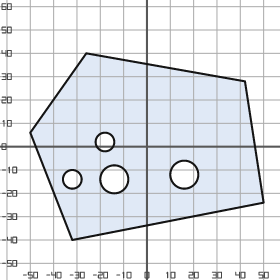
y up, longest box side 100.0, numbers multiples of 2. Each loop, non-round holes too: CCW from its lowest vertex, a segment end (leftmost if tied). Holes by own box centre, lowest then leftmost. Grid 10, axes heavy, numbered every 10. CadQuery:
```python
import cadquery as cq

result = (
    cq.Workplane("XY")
    .moveTo(-32.0, -40.0)
    .lineTo(50.0, -24.0)
    .lineTo(42.0, 28.0)
    .lineTo(-26.0, 40.0)
    .lineTo(-50.0, 6.0)
    .close()
    .moveTo(-32.0, -14.0)
    .circle(4.0)
    .moveTo(-14.0, -14.0)
    .circle(6.0)
    .moveTo(16.0, -12.0)
    .circle(6.0)
    .moveTo(-18.0, 2.0)
    .circle(4.0)
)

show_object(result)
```